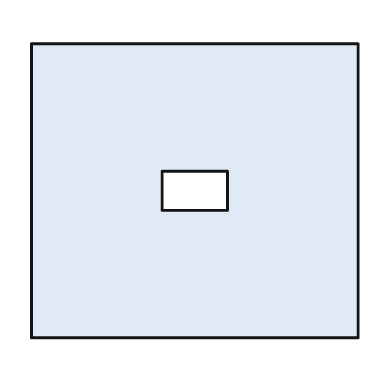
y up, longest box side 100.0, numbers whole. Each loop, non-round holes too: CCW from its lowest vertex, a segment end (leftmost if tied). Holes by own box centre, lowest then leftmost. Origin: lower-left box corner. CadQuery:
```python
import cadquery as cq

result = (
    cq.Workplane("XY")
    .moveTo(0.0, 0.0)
    .lineTo(100.0, 0.0)
    .lineTo(100.0, 90.0)
    .lineTo(0.0, 90.0)
    .close()
    .moveTo(40.0, 39.0)
    .lineTo(60.0, 39.0)
    .lineTo(60.0, 51.0)
    .lineTo(40.0, 51.0)
    .close()
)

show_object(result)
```